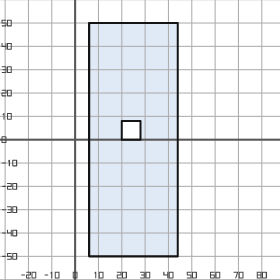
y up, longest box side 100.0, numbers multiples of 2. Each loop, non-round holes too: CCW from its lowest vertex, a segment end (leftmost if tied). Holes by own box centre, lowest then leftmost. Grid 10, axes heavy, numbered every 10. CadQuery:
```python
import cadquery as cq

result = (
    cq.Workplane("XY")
    .moveTo(6.0, -50.0)
    .lineTo(44.0, -50.0)
    .lineTo(44.0, 50.0)
    .lineTo(6.0, 50.0)
    .close()
    .moveTo(20.0, 0.0)
    .lineTo(28.0, 0.0)
    .lineTo(28.0, 8.0)
    .lineTo(20.0, 8.0)
    .close()
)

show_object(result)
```